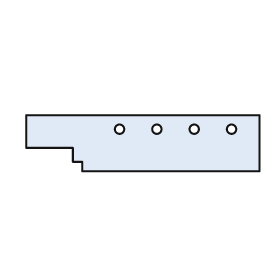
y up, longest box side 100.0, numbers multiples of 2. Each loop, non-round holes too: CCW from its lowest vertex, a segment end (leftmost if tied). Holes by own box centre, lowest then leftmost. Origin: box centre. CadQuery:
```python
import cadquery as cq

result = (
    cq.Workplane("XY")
    .moveTo(-26.0, -12.0)
    .lineTo(50.0, -12.0)
    .lineTo(50.0, 12.0)
    .lineTo(-50.0, 12.0)
    .lineTo(-50.0, -2.0)
    .lineTo(-30.0, -2.0)
    .lineTo(-30.0, -8.0)
    .lineTo(-26.0, -8.0)
    .close()
    .moveTo(-10.0, 6.0)
    .circle(2.0)
    .moveTo(6.0, 6.0)
    .circle(2.0)
    .moveTo(22.0, 6.0)
    .circle(2.0)
    .moveTo(38.0, 6.0)
    .circle(2.0)
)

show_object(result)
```